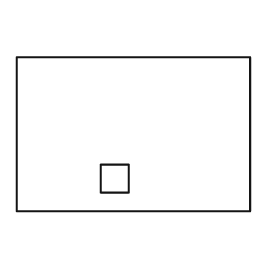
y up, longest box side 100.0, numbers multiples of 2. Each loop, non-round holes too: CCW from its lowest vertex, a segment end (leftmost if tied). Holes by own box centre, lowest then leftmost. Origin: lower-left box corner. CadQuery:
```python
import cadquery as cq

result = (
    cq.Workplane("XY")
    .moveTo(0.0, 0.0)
    .lineTo(100.0, 0.0)
    .lineTo(100.0, 66.0)
    .lineTo(0.0, 66.0)
    .close()
    .moveTo(36.0, 8.0)
    .lineTo(48.0, 8.0)
    .lineTo(48.0, 20.0)
    .lineTo(36.0, 20.0)
    .close()
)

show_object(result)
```